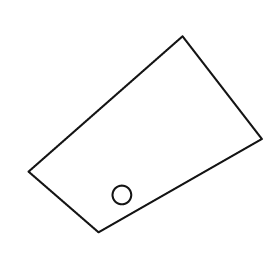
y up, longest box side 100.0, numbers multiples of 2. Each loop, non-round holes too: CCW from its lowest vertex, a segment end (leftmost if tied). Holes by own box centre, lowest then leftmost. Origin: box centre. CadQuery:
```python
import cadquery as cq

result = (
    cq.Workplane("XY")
    .moveTo(-20.0, -42.0)
    .lineTo(50.0, -2.0)
    .lineTo(16.0, 42.0)
    .lineTo(-50.0, -16.0)
    .close()
    .moveTo(-10.0, -26.0)
    .circle(4.0)
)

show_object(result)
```